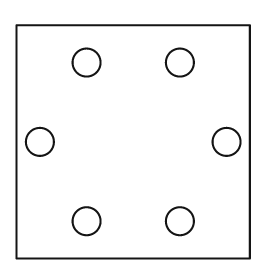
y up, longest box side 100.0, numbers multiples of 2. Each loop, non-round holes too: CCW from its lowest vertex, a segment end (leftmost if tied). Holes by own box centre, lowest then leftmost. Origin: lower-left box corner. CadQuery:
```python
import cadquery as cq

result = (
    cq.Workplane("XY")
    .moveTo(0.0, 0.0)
    .lineTo(100.0, 0.0)
    .lineTo(100.0, 100.0)
    .lineTo(0.0, 100.0)
    .close()
    .moveTo(30.0, 16.0)
    .circle(6.0)
    .moveTo(70.0, 16.0)
    .circle(6.0)
    .moveTo(10.0, 50.0)
    .circle(6.0)
    .moveTo(90.0, 50.0)
    .circle(6.0)
    .moveTo(30.0, 84.0)
    .circle(6.0)
    .moveTo(70.0, 84.0)
    .circle(6.0)
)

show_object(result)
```